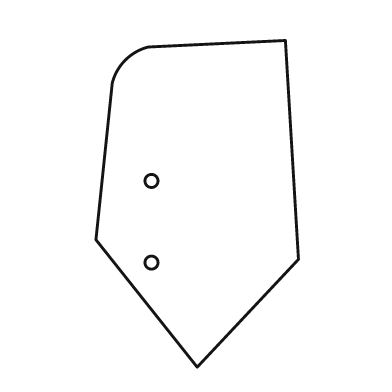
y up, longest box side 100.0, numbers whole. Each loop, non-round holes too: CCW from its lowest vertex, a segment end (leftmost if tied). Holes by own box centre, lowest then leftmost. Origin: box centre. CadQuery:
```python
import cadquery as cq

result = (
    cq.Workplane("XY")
    .moveTo(0.0, -50.0)
    .lineTo(31.0, -17.0)
    .lineTo(27.0, 50.0)
    .lineTo(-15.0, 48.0)
    .threePointArc((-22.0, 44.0), (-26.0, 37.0))
    .lineTo(-31.0, -11.0)
    .close()
    .moveTo(-14.0, -18.0)
    .circle(2.0)
    .moveTo(-14.0, 7.0)
    .circle(2.0)
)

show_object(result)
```